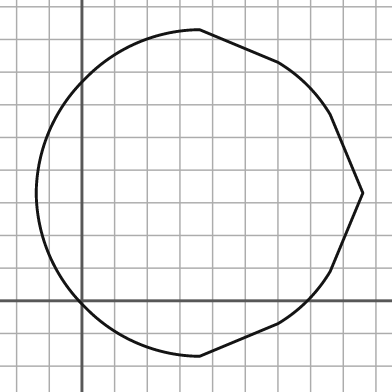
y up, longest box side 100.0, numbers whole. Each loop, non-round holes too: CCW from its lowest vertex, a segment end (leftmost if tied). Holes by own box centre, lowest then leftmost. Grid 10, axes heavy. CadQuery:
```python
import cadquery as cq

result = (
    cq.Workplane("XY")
    .moveTo(36.0, -17.0)
    .lineTo(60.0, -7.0)
    .threePointArc((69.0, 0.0), (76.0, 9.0))
    .lineTo(86.0, 33.0)
    .lineTo(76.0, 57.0)
    .threePointArc((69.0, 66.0), (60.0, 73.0))
    .lineTo(36.0, 83.0)
    .threePointArc((17.0, 79.0), (1.0, 68.0))
    .threePointArc((-10.0, 52.0), (-14.0, 33.0))
    .threePointArc((-10.0, 14.0), (1.0, -2.0))
    .threePointArc((17.0, -13.0), (36.0, -17.0))
    .close()
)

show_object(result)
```